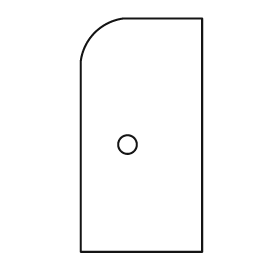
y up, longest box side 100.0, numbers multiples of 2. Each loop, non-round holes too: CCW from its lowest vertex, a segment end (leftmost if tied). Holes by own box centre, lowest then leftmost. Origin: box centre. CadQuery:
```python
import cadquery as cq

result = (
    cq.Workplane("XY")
    .moveTo(-26.0, -50.0)
    .lineTo(26.0, -50.0)
    .lineTo(26.0, 50.0)
    .lineTo(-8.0, 50.0)
    .threePointArc((-20.0, 44.0), (-26.0, 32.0))
    .close()
    .moveTo(-6.0, -4.0)
    .circle(4.0)
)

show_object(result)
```